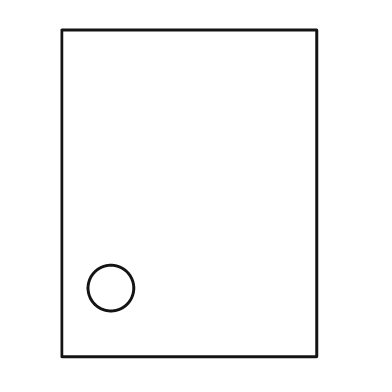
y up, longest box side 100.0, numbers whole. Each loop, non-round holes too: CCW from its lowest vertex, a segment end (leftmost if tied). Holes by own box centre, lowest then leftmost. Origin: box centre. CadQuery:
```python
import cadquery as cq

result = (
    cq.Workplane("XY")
    .moveTo(-39.0, -50.0)
    .lineTo(39.0, -50.0)
    .lineTo(39.0, 50.0)
    .lineTo(-39.0, 50.0)
    .close()
    .moveTo(-24.0, -29.0)
    .circle(7.0)
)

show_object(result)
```